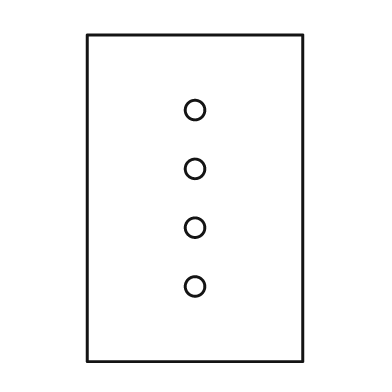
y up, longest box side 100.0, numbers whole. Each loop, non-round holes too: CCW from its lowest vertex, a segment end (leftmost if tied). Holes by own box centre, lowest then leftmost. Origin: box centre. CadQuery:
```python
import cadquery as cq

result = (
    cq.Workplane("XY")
    .moveTo(-33.0, -50.0)
    .lineTo(33.0, -50.0)
    .lineTo(33.0, 50.0)
    .lineTo(-33.0, 50.0)
    .close()
    .moveTo(0.0, -27.0)
    .circle(3.0)
    .moveTo(0.0, -9.0)
    .circle(3.0)
    .moveTo(0.0, 9.0)
    .circle(3.0)
    .moveTo(0.0, 27.0)
    .circle(3.0)
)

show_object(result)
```